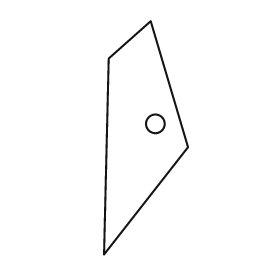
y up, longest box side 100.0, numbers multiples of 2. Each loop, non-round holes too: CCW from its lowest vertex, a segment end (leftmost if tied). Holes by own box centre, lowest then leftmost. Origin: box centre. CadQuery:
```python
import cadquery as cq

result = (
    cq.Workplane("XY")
    .moveTo(-18.0, -50.0)
    .lineTo(18.0, -4.0)
    .lineTo(2.0, 50.0)
    .lineTo(-16.0, 34.0)
    .close()
    .moveTo(4.0, 6.0)
    .circle(4.0)
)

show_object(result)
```